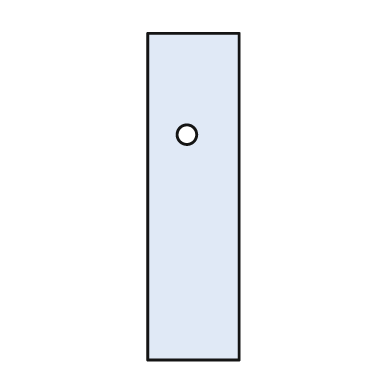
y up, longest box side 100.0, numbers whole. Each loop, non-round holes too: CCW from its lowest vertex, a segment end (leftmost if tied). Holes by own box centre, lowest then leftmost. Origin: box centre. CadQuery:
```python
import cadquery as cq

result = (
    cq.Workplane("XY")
    .moveTo(-14.0, -50.0)
    .lineTo(14.0, -50.0)
    .lineTo(14.0, 50.0)
    .lineTo(-14.0, 50.0)
    .close()
    .moveTo(-2.0, 19.0)
    .circle(3.0)
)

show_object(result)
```